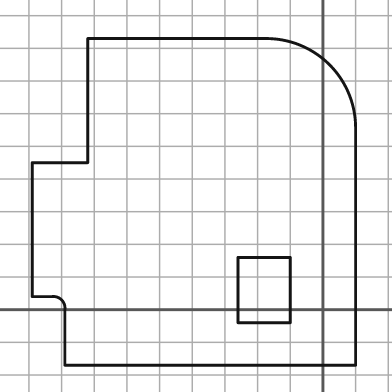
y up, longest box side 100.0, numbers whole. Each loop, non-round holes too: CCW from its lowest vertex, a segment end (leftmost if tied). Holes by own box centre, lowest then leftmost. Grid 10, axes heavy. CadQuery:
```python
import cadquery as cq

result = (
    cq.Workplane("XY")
    .moveTo(-79.0, -17.0)
    .lineTo(10.0, -17.0)
    .lineTo(10.0, 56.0)
    .threePointArc((2.0, 75.0), (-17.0, 83.0))
    .lineTo(-72.0, 83.0)
    .lineTo(-72.0, 45.0)
    .lineTo(-89.0, 45.0)
    .lineTo(-89.0, 4.0)
    .lineTo(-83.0, 4.0)
    .threePointArc((-80.0, 3.0), (-79.0, 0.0))
    .close()
    .moveTo(-26.0, -4.0)
    .lineTo(-10.0, -4.0)
    .lineTo(-10.0, 16.0)
    .lineTo(-26.0, 16.0)
    .close()
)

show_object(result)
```